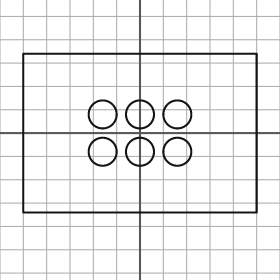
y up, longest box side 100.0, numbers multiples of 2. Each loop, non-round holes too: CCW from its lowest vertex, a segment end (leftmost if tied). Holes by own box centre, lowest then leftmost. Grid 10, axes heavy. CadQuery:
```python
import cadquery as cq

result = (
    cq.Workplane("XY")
    .moveTo(-50.0, -34.0)
    .lineTo(50.0, -34.0)
    .lineTo(50.0, 34.0)
    .lineTo(-50.0, 34.0)
    .close()
    .moveTo(-16.0, -8.0)
    .circle(6.0)
    .moveTo(0.0, -8.0)
    .circle(6.0)
    .moveTo(16.0, -8.0)
    .circle(6.0)
    .moveTo(-16.0, 8.0)
    .circle(6.0)
    .moveTo(0.0, 8.0)
    .circle(6.0)
    .moveTo(16.0, 8.0)
    .circle(6.0)
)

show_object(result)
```